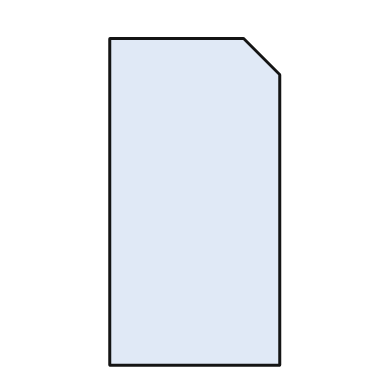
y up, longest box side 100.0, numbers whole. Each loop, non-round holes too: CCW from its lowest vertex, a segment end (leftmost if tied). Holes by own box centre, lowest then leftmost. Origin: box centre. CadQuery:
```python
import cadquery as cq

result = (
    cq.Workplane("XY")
    .moveTo(-26.0, -50.0)
    .lineTo(26.0, -50.0)
    .lineTo(26.0, 39.0)
    .lineTo(15.0, 50.0)
    .lineTo(-26.0, 50.0)
    .close()
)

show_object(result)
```